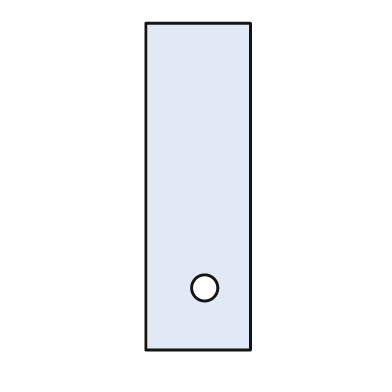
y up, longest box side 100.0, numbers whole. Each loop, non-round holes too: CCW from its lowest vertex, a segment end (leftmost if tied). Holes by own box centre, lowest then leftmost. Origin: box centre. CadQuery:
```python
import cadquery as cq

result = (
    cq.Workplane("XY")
    .moveTo(-16.0, -50.0)
    .lineTo(16.0, -50.0)
    .lineTo(16.0, 50.0)
    .lineTo(-16.0, 50.0)
    .close()
    .moveTo(2.0, -31.0)
    .circle(4.0)
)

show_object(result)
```